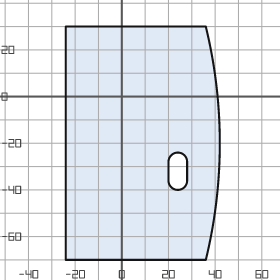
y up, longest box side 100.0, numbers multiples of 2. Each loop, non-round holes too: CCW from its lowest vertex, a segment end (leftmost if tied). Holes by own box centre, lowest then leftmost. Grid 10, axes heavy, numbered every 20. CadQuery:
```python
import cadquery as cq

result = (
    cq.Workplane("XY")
    .moveTo(-24.0, -70.0)
    .lineTo(36.0, -70.0)
    .threePointArc((42.0, -20.0), (36.0, 30.0))
    .lineTo(-24.0, 30.0)
    .close()
    .moveTo(20.0, -36.0)
    .threePointArc((24.0, -40.0), (28.0, -36.0))
    .lineTo(28.0, -28.0)
    .threePointArc((24.0, -24.0), (20.0, -28.0))
    .close()
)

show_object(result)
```